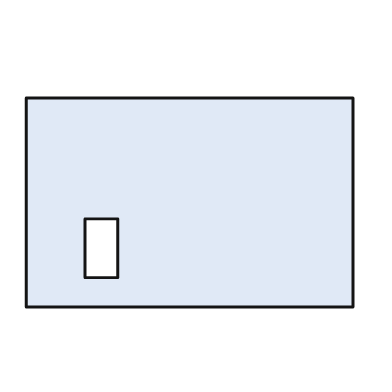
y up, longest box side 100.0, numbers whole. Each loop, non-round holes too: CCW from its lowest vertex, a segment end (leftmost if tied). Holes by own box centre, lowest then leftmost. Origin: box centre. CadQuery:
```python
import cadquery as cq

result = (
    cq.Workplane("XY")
    .moveTo(-50.0, -32.0)
    .lineTo(50.0, -32.0)
    .lineTo(50.0, 32.0)
    .lineTo(-50.0, 32.0)
    .close()
    .moveTo(-32.0, -23.0)
    .lineTo(-22.0, -23.0)
    .lineTo(-22.0, -5.0)
    .lineTo(-32.0, -5.0)
    .close()
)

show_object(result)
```